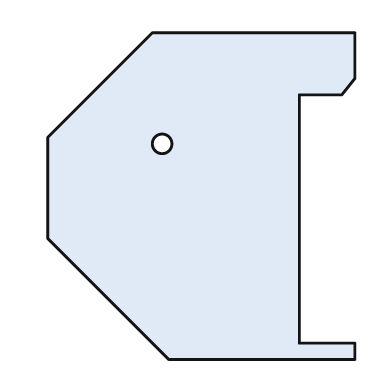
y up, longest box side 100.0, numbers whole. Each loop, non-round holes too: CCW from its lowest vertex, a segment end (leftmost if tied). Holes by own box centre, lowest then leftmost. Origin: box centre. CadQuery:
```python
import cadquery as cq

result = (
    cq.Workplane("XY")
    .moveTo(-10.0, -50.0)
    .lineTo(47.0, -50.0)
    .lineTo(47.0, -45.0)
    .lineTo(30.0, -45.0)
    .lineTo(30.0, 31.0)
    .lineTo(43.0, 31.0)
    .lineTo(47.0, 36.0)
    .lineTo(47.0, 50.0)
    .lineTo(-15.0, 50.0)
    .lineTo(-47.0, 18.0)
    .lineTo(-47.0, -13.0)
    .close()
    .moveTo(-12.0, 16.0)
    .circle(3.0)
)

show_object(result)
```